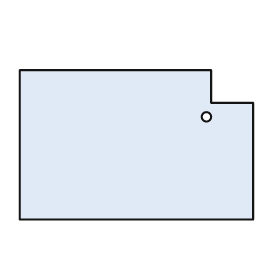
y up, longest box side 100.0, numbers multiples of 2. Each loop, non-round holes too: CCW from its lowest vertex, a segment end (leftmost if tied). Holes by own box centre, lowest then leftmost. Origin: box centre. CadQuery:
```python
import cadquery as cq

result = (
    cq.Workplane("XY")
    .moveTo(-50.0, -32.0)
    .lineTo(50.0, -32.0)
    .lineTo(50.0, 18.0)
    .lineTo(32.0, 18.0)
    .lineTo(32.0, 32.0)
    .lineTo(-50.0, 32.0)
    .close()
    .moveTo(30.0, 12.0)
    .circle(2.0)
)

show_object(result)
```